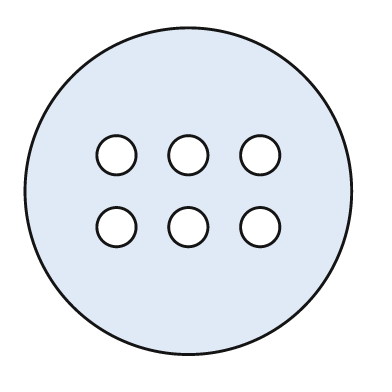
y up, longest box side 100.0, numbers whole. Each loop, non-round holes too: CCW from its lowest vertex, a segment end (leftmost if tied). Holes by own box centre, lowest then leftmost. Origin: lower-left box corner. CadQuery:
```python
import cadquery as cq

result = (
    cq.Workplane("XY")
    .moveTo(50.0, 50.0)
    .circle(50.0)
    .moveTo(28.0, 39.0)
    .circle(6.0)
    .moveTo(50.0, 39.0)
    .circle(6.0)
    .moveTo(72.0, 39.0)
    .circle(6.0)
    .moveTo(28.0, 61.0)
    .circle(6.0)
    .moveTo(50.0, 61.0)
    .circle(6.0)
    .moveTo(72.0, 61.0)
    .circle(6.0)
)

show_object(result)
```